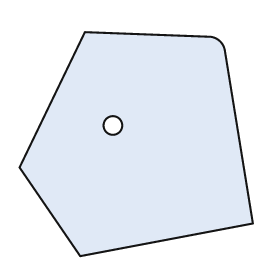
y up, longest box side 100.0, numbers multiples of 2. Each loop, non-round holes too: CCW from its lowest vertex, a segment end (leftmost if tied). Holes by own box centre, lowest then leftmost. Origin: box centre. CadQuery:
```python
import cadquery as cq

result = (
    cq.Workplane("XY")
    .moveTo(-24.0, -48.0)
    .lineTo(50.0, -34.0)
    .lineTo(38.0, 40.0)
    .threePointArc((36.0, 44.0), (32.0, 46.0))
    .lineTo(-22.0, 48.0)
    .lineTo(-50.0, -10.0)
    .close()
    .moveTo(-10.0, 8.0)
    .circle(4.0)
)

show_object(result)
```